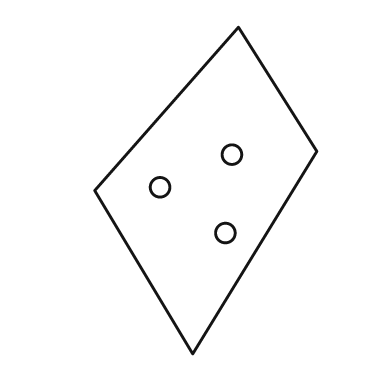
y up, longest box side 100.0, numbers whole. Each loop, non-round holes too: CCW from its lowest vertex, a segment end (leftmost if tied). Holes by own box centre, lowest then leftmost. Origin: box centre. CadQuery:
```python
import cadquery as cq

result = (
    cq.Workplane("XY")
    .moveTo(-4.0, -50.0)
    .lineTo(34.0, 12.0)
    .lineTo(10.0, 50.0)
    .lineTo(-34.0, 0.0)
    .close()
    .moveTo(6.0, -13.0)
    .circle(3.0)
    .moveTo(-14.0, 1.0)
    .circle(3.0)
    .moveTo(8.0, 11.0)
    .circle(3.0)
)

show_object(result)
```